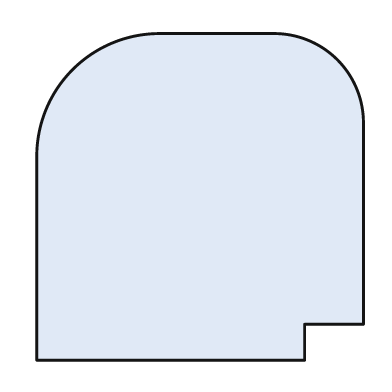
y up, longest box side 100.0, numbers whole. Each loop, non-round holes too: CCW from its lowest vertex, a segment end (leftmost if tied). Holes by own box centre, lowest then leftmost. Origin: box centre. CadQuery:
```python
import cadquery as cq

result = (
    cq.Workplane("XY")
    .moveTo(-50.0, -50.0)
    .lineTo(32.0, -50.0)
    .lineTo(32.0, -39.0)
    .lineTo(50.0, -39.0)
    .lineTo(50.0, 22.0)
    .threePointArc((42.0, 42.0), (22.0, 50.0))
    .lineTo(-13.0, 50.0)
    .threePointArc((-39.0, 39.0), (-50.0, 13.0))
    .close()
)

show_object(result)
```